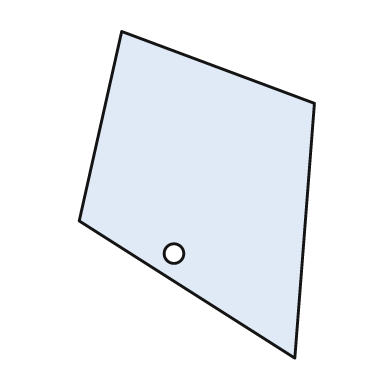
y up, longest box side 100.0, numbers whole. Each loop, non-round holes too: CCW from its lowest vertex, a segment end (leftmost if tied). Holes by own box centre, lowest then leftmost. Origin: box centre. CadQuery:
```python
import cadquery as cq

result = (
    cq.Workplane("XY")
    .moveTo(30.0, -50.0)
    .lineTo(36.0, 28.0)
    .lineTo(-23.0, 50.0)
    .lineTo(-36.0, -8.0)
    .close()
    .moveTo(-7.0, -18.0)
    .circle(3.0)
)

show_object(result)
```